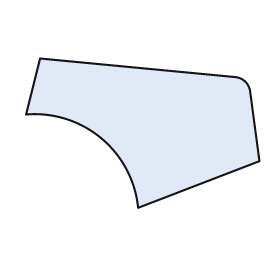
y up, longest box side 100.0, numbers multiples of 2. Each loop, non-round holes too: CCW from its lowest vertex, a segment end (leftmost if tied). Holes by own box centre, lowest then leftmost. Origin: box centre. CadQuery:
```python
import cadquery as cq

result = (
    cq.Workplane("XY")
    .moveTo(-2.0, -32.0)
    .lineTo(50.0, -12.0)
    .lineTo(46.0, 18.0)
    .threePointArc((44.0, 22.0), (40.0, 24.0))
    .lineTo(-44.0, 32.0)
    .lineTo(-50.0, 8.0)
    .threePointArc((-18.0, -2.0), (-2.0, -32.0))
    .close()
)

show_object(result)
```